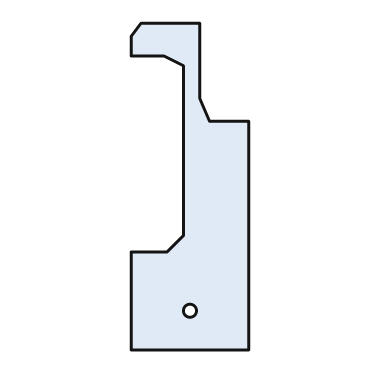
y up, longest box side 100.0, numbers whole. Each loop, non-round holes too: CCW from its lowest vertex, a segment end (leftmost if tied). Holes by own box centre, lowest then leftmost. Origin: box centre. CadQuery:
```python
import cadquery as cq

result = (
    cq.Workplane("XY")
    .moveTo(-18.0, -50.0)
    .lineTo(18.0, -50.0)
    .lineTo(18.0, 20.0)
    .lineTo(6.0, 20.0)
    .lineTo(3.0, 27.0)
    .lineTo(3.0, 50.0)
    .lineTo(-15.0, 50.0)
    .lineTo(-18.0, 46.0)
    .lineTo(-18.0, 40.0)
    .lineTo(-8.0, 40.0)
    .lineTo(-2.0, 37.0)
    .lineTo(-2.0, -15.0)
    .lineTo(-7.0, -20.0)
    .lineTo(-18.0, -20.0)
    .close()
    .moveTo(0.0, -38.0)
    .circle(2.0)
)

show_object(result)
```